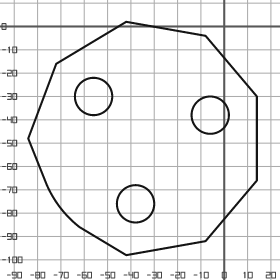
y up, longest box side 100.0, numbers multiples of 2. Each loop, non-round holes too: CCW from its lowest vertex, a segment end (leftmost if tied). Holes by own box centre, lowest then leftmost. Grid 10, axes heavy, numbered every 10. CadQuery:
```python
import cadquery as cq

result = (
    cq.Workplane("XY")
    .moveTo(-42.0, -98.0)
    .lineTo(-8.0, -92.0)
    .lineTo(14.0, -66.0)
    .lineTo(14.0, -30.0)
    .lineTo(-8.0, -4.0)
    .lineTo(-42.0, 2.0)
    .lineTo(-72.0, -16.0)
    .lineTo(-84.0, -48.0)
    .lineTo(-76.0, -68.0)
    .threePointArc((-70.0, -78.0), (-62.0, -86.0))
    .close()
    .moveTo(-38.0, -76.0)
    .circle(8.0)
    .moveTo(-6.0, -38.0)
    .circle(8.0)
    .moveTo(-56.0, -30.0)
    .circle(8.0)
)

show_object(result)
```